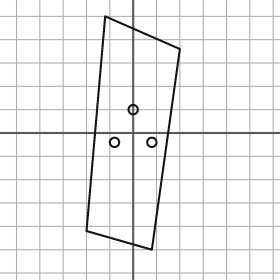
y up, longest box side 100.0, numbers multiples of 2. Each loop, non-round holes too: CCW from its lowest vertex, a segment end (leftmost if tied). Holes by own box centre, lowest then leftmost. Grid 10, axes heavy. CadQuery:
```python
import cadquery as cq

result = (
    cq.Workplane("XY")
    .moveTo(8.0, -50.0)
    .lineTo(20.0, 36.0)
    .lineTo(-12.0, 50.0)
    .lineTo(-20.0, -42.0)
    .close()
    .moveTo(-8.0, -4.0)
    .circle(2.0)
    .moveTo(8.0, -4.0)
    .circle(2.0)
    .moveTo(0.0, 10.0)
    .circle(2.0)
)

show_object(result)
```